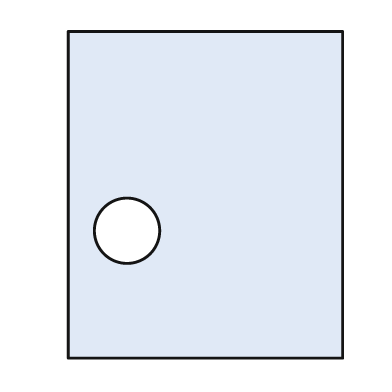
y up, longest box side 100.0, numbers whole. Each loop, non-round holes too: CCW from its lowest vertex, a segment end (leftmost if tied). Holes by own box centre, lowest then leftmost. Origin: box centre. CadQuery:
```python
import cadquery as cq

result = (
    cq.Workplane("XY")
    .moveTo(-42.0, -50.0)
    .lineTo(42.0, -50.0)
    .lineTo(42.0, 50.0)
    .lineTo(-42.0, 50.0)
    .close()
    .moveTo(-24.0, -11.0)
    .circle(10.0)
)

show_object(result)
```